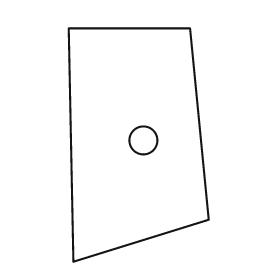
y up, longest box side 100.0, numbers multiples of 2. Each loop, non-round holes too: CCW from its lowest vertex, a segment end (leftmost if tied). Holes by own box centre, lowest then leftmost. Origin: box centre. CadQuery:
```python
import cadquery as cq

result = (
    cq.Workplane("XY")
    .moveTo(-28.0, -50.0)
    .lineTo(30.0, -32.0)
    .lineTo(22.0, 50.0)
    .lineTo(-30.0, 50.0)
    .close()
    .moveTo(2.0, 2.0)
    .circle(6.0)
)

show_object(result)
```